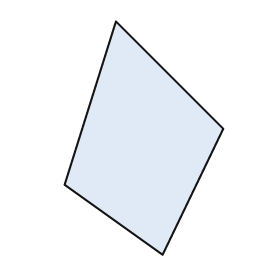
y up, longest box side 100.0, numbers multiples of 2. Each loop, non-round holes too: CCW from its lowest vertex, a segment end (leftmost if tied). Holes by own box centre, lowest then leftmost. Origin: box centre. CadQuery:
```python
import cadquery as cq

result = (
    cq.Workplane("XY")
    .moveTo(8.0, -50.0)
    .lineTo(34.0, 4.0)
    .lineTo(-12.0, 50.0)
    .lineTo(-34.0, -20.0)
    .close()
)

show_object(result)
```